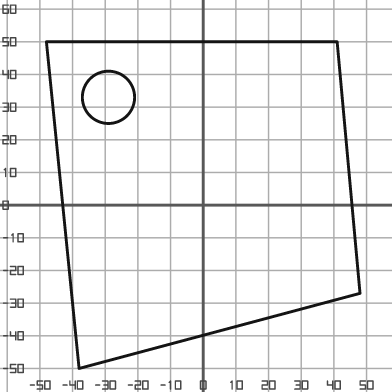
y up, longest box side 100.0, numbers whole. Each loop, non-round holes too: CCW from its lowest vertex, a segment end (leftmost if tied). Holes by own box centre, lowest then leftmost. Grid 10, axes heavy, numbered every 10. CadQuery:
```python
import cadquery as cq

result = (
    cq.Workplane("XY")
    .moveTo(-38.0, -50.0)
    .lineTo(48.0, -27.0)
    .lineTo(41.0, 50.0)
    .lineTo(-48.0, 50.0)
    .close()
    .moveTo(-29.0, 33.0)
    .circle(8.0)
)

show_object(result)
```